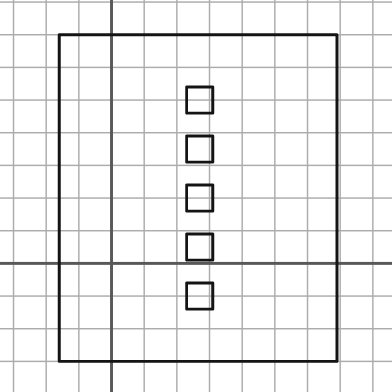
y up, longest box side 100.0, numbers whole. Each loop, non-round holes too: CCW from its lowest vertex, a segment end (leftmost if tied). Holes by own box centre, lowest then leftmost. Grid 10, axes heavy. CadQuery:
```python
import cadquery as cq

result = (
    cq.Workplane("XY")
    .moveTo(-16.0, -30.0)
    .lineTo(69.0, -30.0)
    .lineTo(69.0, 70.0)
    .lineTo(-16.0, 70.0)
    .close()
    .moveTo(23.0, -14.0)
    .lineTo(31.0, -14.0)
    .lineTo(31.0, -6.0)
    .lineTo(23.0, -6.0)
    .close()
    .moveTo(23.0, 1.0)
    .lineTo(31.0, 1.0)
    .lineTo(31.0, 9.0)
    .lineTo(23.0, 9.0)
    .close()
    .moveTo(23.0, 16.0)
    .lineTo(31.0, 16.0)
    .lineTo(31.0, 24.0)
    .lineTo(23.0, 24.0)
    .close()
    .moveTo(23.0, 31.0)
    .lineTo(31.0, 31.0)
    .lineTo(31.0, 39.0)
    .lineTo(23.0, 39.0)
    .close()
    .moveTo(23.0, 46.0)
    .lineTo(31.0, 46.0)
    .lineTo(31.0, 54.0)
    .lineTo(23.0, 54.0)
    .close()
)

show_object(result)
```